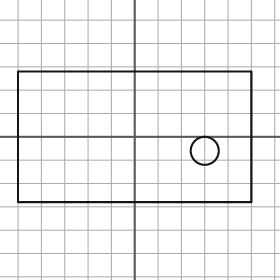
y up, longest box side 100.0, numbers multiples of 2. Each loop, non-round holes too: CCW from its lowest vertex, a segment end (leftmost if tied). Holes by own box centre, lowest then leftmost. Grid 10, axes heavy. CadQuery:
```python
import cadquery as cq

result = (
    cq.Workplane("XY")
    .moveTo(-50.0, -28.0)
    .lineTo(50.0, -28.0)
    .lineTo(50.0, 28.0)
    .lineTo(-50.0, 28.0)
    .close()
    .moveTo(30.0, -6.0)
    .circle(6.0)
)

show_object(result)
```